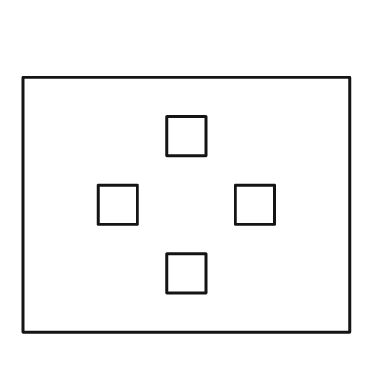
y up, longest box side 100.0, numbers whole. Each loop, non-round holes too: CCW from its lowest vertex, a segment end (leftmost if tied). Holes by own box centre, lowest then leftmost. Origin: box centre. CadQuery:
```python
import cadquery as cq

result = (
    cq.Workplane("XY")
    .moveTo(-50.0, -39.0)
    .lineTo(50.0, -39.0)
    .lineTo(50.0, 39.0)
    .lineTo(-50.0, 39.0)
    .close()
    .moveTo(-6.0, -27.0)
    .lineTo(6.0, -27.0)
    .lineTo(6.0, -15.0)
    .lineTo(-6.0, -15.0)
    .close()
    .moveTo(-27.0, -6.0)
    .lineTo(-15.0, -6.0)
    .lineTo(-15.0, 6.0)
    .lineTo(-27.0, 6.0)
    .close()
    .moveTo(15.0, -6.0)
    .lineTo(27.0, -6.0)
    .lineTo(27.0, 6.0)
    .lineTo(15.0, 6.0)
    .close()
    .moveTo(-6.0, 15.0)
    .lineTo(6.0, 15.0)
    .lineTo(6.0, 27.0)
    .lineTo(-6.0, 27.0)
    .close()
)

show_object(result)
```